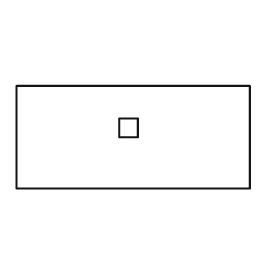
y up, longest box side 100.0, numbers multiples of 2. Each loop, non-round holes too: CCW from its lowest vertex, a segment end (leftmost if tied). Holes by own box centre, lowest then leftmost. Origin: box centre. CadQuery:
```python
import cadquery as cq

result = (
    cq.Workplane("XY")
    .moveTo(-50.0, -22.0)
    .lineTo(50.0, -22.0)
    .lineTo(50.0, 22.0)
    .lineTo(-50.0, 22.0)
    .close()
    .moveTo(-6.0, 0.0)
    .lineTo(2.0, 0.0)
    .lineTo(2.0, 8.0)
    .lineTo(-6.0, 8.0)
    .close()
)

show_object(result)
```